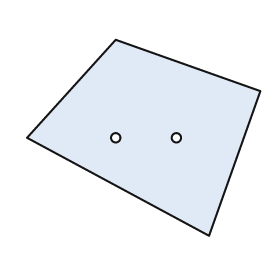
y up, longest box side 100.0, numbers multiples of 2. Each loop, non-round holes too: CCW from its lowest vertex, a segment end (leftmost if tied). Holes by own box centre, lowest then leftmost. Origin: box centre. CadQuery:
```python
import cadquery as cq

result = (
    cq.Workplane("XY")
    .moveTo(28.0, -42.0)
    .lineTo(50.0, 20.0)
    .lineTo(-12.0, 42.0)
    .lineTo(-50.0, 0.0)
    .close()
    .moveTo(-12.0, 0.0)
    .circle(2.0)
    .moveTo(14.0, 0.0)
    .circle(2.0)
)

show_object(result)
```